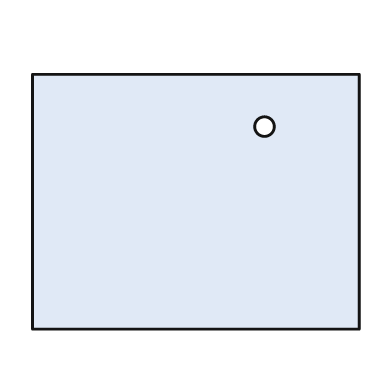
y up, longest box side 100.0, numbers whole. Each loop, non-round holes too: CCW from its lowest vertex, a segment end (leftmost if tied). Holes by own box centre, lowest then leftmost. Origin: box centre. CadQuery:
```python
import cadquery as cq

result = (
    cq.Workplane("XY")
    .moveTo(-50.0, -39.0)
    .lineTo(50.0, -39.0)
    .lineTo(50.0, 39.0)
    .lineTo(-50.0, 39.0)
    .close()
    .moveTo(21.0, 23.0)
    .circle(3.0)
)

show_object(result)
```